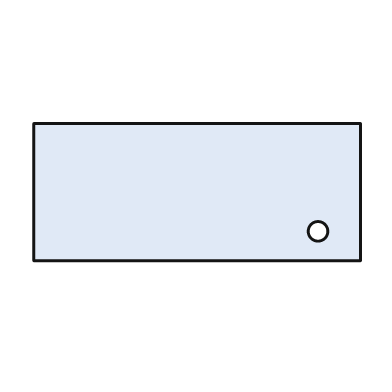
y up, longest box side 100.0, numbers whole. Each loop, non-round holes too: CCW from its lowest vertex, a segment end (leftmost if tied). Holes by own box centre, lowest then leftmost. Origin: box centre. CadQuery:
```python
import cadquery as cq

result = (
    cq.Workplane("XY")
    .moveTo(-50.0, -21.0)
    .lineTo(50.0, -21.0)
    .lineTo(50.0, 21.0)
    .lineTo(-50.0, 21.0)
    .close()
    .moveTo(37.0, -12.0)
    .circle(3.0)
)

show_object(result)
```